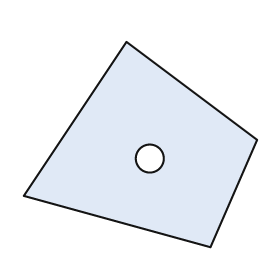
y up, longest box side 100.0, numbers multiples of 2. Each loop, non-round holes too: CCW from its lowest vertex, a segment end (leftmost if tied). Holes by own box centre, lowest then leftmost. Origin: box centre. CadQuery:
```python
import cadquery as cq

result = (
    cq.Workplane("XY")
    .moveTo(30.0, -44.0)
    .lineTo(50.0, 2.0)
    .lineTo(-6.0, 44.0)
    .lineTo(-50.0, -22.0)
    .close()
    .moveTo(4.0, -6.0)
    .circle(6.0)
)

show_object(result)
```